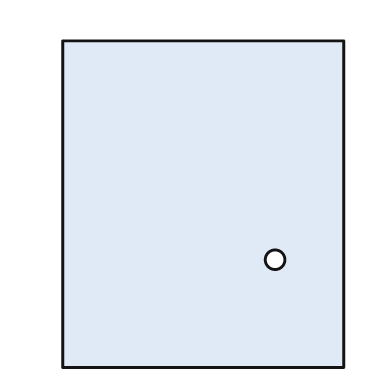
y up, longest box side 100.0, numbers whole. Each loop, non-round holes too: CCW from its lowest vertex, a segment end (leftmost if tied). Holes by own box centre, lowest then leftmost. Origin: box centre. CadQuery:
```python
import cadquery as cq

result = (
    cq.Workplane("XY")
    .moveTo(-43.0, -50.0)
    .lineTo(43.0, -50.0)
    .lineTo(43.0, 50.0)
    .lineTo(-43.0, 50.0)
    .close()
    .moveTo(22.0, -17.0)
    .circle(3.0)
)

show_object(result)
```